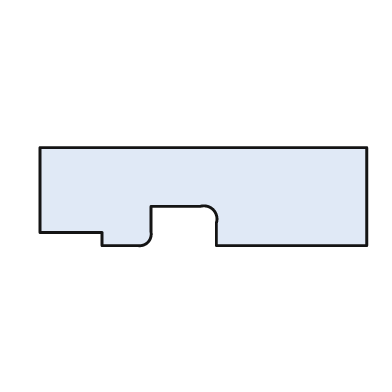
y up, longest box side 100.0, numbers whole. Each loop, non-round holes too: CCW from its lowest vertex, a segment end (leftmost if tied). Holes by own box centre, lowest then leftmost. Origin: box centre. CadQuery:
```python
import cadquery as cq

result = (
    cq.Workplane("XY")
    .moveTo(-31.0, -15.0)
    .lineTo(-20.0, -15.0)
    .threePointArc((-17.0, -14.0), (-16.0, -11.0))
    .lineTo(-16.0, -3.0)
    .lineTo(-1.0, -3.0)
    .threePointArc((3.0, -4.0), (4.0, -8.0))
    .lineTo(4.0, -15.0)
    .lineTo(50.0, -15.0)
    .lineTo(50.0, 15.0)
    .lineTo(-50.0, 15.0)
    .lineTo(-50.0, -11.0)
    .lineTo(-31.0, -11.0)
    .close()
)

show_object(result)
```